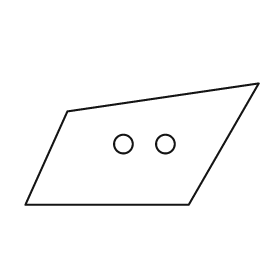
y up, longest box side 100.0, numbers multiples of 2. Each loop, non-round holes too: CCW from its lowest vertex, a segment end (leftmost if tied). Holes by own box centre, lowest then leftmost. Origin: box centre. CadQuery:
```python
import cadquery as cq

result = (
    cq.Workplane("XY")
    .moveTo(-50.0, -26.0)
    .lineTo(20.0, -26.0)
    .lineTo(50.0, 26.0)
    .lineTo(-32.0, 14.0)
    .close()
    .moveTo(-8.0, 0.0)
    .circle(4.0)
    .moveTo(10.0, 0.0)
    .circle(4.0)
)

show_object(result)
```